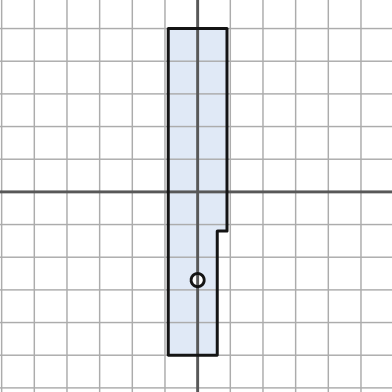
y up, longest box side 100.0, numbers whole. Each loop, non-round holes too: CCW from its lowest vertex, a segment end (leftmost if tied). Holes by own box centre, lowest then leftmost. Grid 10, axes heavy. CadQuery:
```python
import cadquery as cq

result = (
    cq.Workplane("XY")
    .moveTo(-9.0, -50.0)
    .lineTo(6.0, -50.0)
    .lineTo(6.0, -12.0)
    .lineTo(9.0, -12.0)
    .lineTo(9.0, 50.0)
    .lineTo(-9.0, 50.0)
    .close()
    .moveTo(0.0, -27.0)
    .circle(2.0)
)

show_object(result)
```